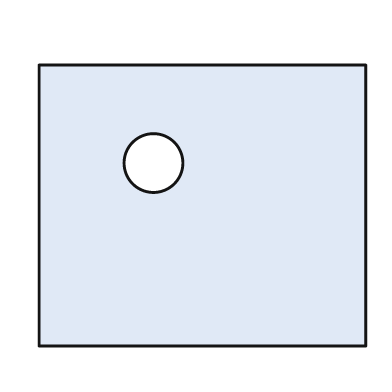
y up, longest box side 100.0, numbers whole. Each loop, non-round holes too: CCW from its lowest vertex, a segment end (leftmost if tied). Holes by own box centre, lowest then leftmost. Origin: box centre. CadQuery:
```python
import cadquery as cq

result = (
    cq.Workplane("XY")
    .moveTo(-50.0, -43.0)
    .lineTo(50.0, -43.0)
    .lineTo(50.0, 43.0)
    .lineTo(-50.0, 43.0)
    .close()
    .moveTo(-15.0, 13.0)
    .circle(9.0)
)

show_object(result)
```